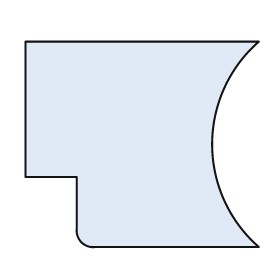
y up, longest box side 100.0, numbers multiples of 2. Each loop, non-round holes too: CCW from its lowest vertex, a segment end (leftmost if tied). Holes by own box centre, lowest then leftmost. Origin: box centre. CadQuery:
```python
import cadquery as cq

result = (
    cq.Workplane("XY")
    .moveTo(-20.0, -44.0)
    .lineTo(50.0, -44.0)
    .threePointArc((30.0, 0.0), (50.0, 44.0))
    .lineTo(-50.0, 44.0)
    .lineTo(-50.0, -14.0)
    .lineTo(-28.0, -14.0)
    .lineTo(-28.0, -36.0)
    .threePointArc((-26.0, -42.0), (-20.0, -44.0))
    .close()
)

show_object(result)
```